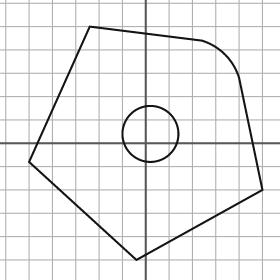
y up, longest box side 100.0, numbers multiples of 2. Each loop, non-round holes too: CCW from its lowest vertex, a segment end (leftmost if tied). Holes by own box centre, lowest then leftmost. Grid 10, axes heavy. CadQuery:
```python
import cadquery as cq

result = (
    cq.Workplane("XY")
    .moveTo(-4.0, -50.0)
    .lineTo(50.0, -20.0)
    .lineTo(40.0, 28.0)
    .threePointArc((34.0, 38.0), (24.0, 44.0))
    .lineTo(-24.0, 50.0)
    .lineTo(-50.0, -8.0)
    .close()
    .moveTo(2.0, 4.0)
    .circle(12.0)
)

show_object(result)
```